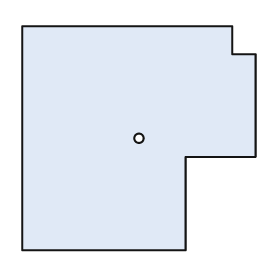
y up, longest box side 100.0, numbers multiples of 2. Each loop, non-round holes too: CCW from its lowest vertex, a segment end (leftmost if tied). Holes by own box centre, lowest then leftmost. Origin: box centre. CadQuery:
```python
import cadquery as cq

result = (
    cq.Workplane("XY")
    .moveTo(-50.0, -48.0)
    .lineTo(20.0, -48.0)
    .lineTo(20.0, -8.0)
    .lineTo(50.0, -8.0)
    .lineTo(50.0, 36.0)
    .lineTo(40.0, 36.0)
    .lineTo(40.0, 48.0)
    .lineTo(-50.0, 48.0)
    .close()
    .moveTo(0.0, 0.0)
    .circle(2.0)
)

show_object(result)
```